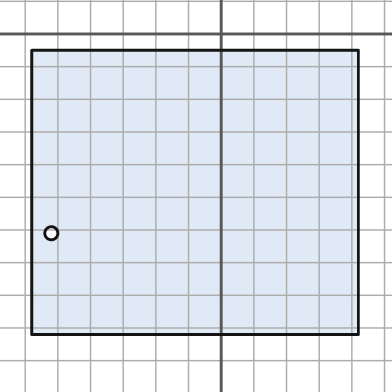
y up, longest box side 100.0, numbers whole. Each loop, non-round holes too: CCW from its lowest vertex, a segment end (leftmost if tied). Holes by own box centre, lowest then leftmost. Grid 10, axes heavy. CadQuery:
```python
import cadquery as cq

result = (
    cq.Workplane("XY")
    .moveTo(-58.0, -92.0)
    .lineTo(42.0, -92.0)
    .lineTo(42.0, -5.0)
    .lineTo(-58.0, -5.0)
    .close()
    .moveTo(-52.0, -61.0)
    .circle(2.0)
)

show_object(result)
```